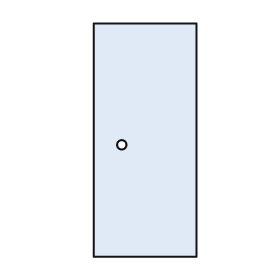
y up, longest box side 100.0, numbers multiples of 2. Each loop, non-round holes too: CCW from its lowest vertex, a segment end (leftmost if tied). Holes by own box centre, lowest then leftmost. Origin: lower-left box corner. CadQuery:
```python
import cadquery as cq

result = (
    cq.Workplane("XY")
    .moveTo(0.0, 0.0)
    .lineTo(44.0, 0.0)
    .lineTo(44.0, 100.0)
    .lineTo(0.0, 100.0)
    .close()
    .moveTo(12.0, 48.0)
    .circle(2.0)
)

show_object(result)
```